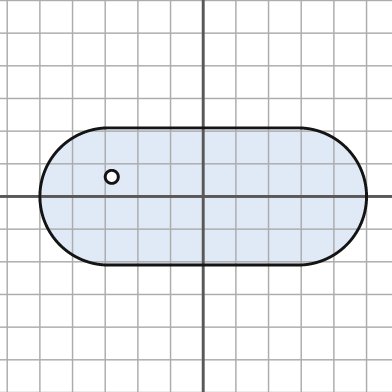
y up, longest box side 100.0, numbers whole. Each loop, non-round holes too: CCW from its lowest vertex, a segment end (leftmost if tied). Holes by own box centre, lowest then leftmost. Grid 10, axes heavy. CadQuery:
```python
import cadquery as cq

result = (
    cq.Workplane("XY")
    .moveTo(-29.0, -21.0)
    .lineTo(29.0, -21.0)
    .threePointArc((50.0, 0.0), (29.0, 21.0))
    .lineTo(-29.0, 21.0)
    .threePointArc((-50.0, 0.0), (-29.0, -21.0))
    .close()
    .moveTo(-28.0, 6.0)
    .circle(2.0)
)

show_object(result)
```